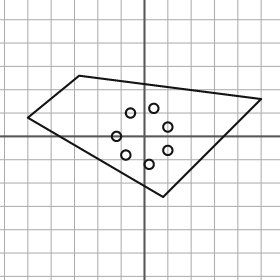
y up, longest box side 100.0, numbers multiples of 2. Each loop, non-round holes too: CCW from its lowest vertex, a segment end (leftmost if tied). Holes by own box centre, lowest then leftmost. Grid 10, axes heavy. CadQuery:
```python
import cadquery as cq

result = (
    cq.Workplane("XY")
    .moveTo(8.0, -26.0)
    .lineTo(50.0, 16.0)
    .lineTo(-28.0, 26.0)
    .lineTo(-50.0, 8.0)
    .close()
    .moveTo(2.0, -12.0)
    .circle(2.0)
    .moveTo(-8.0, -8.0)
    .circle(2.0)
    .moveTo(10.0, -6.0)
    .circle(2.0)
    .moveTo(-12.0, 0.0)
    .circle(2.0)
    .moveTo(10.0, 4.0)
    .circle(2.0)
    .moveTo(-6.0, 10.0)
    .circle(2.0)
    .moveTo(4.0, 12.0)
    .circle(2.0)
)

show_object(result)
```